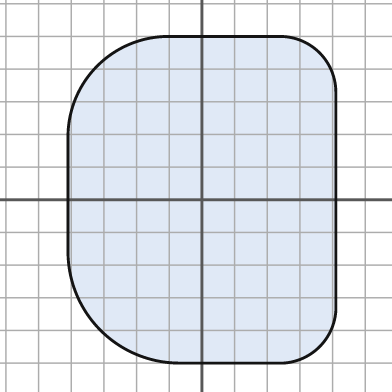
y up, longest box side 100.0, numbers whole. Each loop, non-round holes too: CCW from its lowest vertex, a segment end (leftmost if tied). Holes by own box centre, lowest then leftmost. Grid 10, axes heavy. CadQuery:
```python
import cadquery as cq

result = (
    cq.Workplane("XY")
    .moveTo(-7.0, -50.0)
    .lineTo(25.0, -50.0)
    .threePointArc((36.0, -45.0), (41.0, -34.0))
    .lineTo(41.0, 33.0)
    .threePointArc((36.0, 45.0), (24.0, 50.0))
    .lineTo(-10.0, 50.0)
    .threePointArc((-32.0, 41.0), (-41.0, 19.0))
    .lineTo(-41.0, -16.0)
    .threePointArc((-31.0, -40.0), (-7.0, -50.0))
    .close()
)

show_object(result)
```